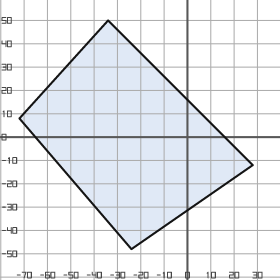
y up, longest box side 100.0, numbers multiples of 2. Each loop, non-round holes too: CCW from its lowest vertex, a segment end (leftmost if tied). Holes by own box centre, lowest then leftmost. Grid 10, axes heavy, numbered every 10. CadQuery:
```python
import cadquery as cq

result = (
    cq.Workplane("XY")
    .moveTo(-24.0, -48.0)
    .lineTo(28.0, -12.0)
    .lineTo(-34.0, 50.0)
    .lineTo(-72.0, 8.0)
    .close()
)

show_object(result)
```